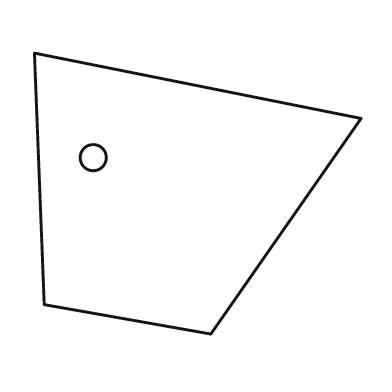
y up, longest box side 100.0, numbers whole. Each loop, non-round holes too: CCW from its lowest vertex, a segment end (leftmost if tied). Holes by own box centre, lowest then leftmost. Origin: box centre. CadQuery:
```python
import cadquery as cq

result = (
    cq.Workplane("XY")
    .moveTo(4.0, -43.0)
    .lineTo(50.0, 23.0)
    .lineTo(-50.0, 43.0)
    .lineTo(-47.0, -34.0)
    .close()
    .moveTo(-32.0, 11.0)
    .circle(4.0)
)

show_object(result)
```